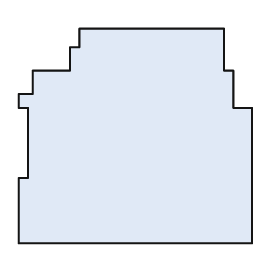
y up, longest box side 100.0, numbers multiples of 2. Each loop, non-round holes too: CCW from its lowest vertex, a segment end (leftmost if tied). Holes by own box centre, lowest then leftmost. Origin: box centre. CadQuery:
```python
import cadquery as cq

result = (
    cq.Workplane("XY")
    .moveTo(-50.0, -46.0)
    .lineTo(50.0, -46.0)
    .lineTo(50.0, 12.0)
    .lineTo(42.0, 12.0)
    .lineTo(42.0, 28.0)
    .lineTo(38.0, 28.0)
    .lineTo(38.0, 46.0)
    .lineTo(-24.0, 46.0)
    .lineTo(-24.0, 38.0)
    .lineTo(-28.0, 38.0)
    .lineTo(-28.0, 28.0)
    .lineTo(-44.0, 28.0)
    .lineTo(-44.0, 18.0)
    .lineTo(-50.0, 18.0)
    .lineTo(-50.0, 12.0)
    .lineTo(-46.0, 12.0)
    .lineTo(-46.0, -18.0)
    .lineTo(-50.0, -18.0)
    .close()
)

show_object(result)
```